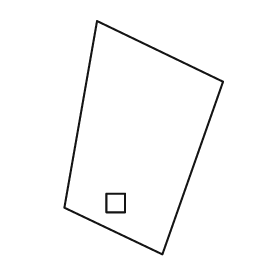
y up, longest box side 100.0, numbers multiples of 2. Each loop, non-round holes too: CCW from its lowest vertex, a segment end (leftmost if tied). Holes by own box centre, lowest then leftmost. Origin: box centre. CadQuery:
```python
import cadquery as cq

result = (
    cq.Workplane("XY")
    .moveTo(8.0, -50.0)
    .lineTo(34.0, 24.0)
    .lineTo(-20.0, 50.0)
    .lineTo(-34.0, -30.0)
    .close()
    .moveTo(-16.0, -32.0)
    .lineTo(-8.0, -32.0)
    .lineTo(-8.0, -24.0)
    .lineTo(-16.0, -24.0)
    .close()
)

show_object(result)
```